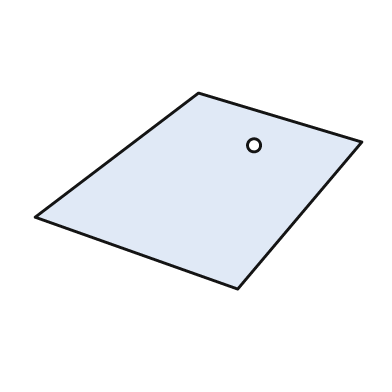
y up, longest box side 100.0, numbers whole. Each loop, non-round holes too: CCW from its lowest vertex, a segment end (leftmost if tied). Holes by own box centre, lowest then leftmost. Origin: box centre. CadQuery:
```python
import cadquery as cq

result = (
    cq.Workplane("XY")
    .moveTo(12.0, -30.0)
    .lineTo(50.0, 15.0)
    .lineTo(0.0, 30.0)
    .lineTo(-50.0, -8.0)
    .close()
    .moveTo(17.0, 14.0)
    .circle(2.0)
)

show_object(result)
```